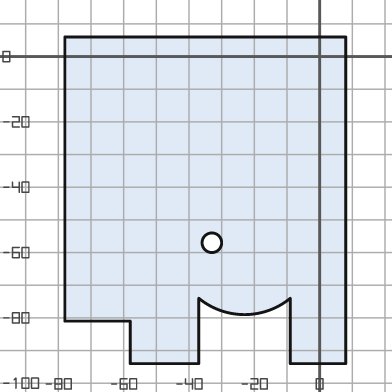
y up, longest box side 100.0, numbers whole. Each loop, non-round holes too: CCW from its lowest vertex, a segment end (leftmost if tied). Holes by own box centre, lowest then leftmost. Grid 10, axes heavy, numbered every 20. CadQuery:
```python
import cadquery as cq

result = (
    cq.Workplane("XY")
    .moveTo(-58.0, -94.0)
    .lineTo(-37.0, -94.0)
    .lineTo(-37.0, -74.0)
    .threePointArc((-23.0, -79.0), (-9.0, -74.0))
    .lineTo(-9.0, -94.0)
    .lineTo(8.0, -94.0)
    .lineTo(8.0, 6.0)
    .lineTo(-78.0, 6.0)
    .lineTo(-78.0, -81.0)
    .lineTo(-58.0, -81.0)
    .close()
    .moveTo(-33.0, -57.0)
    .circle(3.0)
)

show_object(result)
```